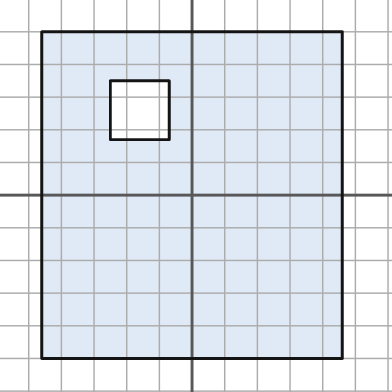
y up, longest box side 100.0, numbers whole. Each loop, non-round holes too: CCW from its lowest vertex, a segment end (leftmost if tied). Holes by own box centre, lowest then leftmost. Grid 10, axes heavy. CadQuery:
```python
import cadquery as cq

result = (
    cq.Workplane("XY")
    .moveTo(-46.0, -50.0)
    .lineTo(46.0, -50.0)
    .lineTo(46.0, 50.0)
    .lineTo(-46.0, 50.0)
    .close()
    .moveTo(-25.0, 17.0)
    .lineTo(-7.0, 17.0)
    .lineTo(-7.0, 35.0)
    .lineTo(-25.0, 35.0)
    .close()
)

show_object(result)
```